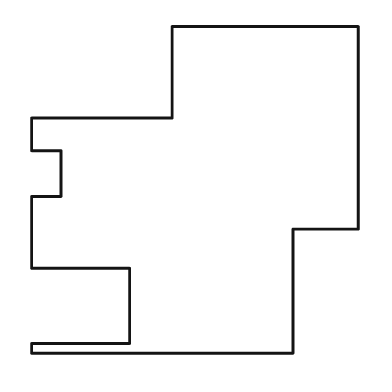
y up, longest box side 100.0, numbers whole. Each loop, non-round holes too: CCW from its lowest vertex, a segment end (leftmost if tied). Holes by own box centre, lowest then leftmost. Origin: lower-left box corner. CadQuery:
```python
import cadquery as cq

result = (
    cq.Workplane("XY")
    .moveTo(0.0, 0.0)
    .lineTo(80.0, 0.0)
    .lineTo(80.0, 38.0)
    .lineTo(100.0, 38.0)
    .lineTo(100.0, 100.0)
    .lineTo(43.0, 100.0)
    .lineTo(43.0, 72.0)
    .lineTo(0.0, 72.0)
    .lineTo(0.0, 62.0)
    .lineTo(9.0, 62.0)
    .lineTo(9.0, 48.0)
    .lineTo(0.0, 48.0)
    .lineTo(0.0, 26.0)
    .lineTo(30.0, 26.0)
    .lineTo(30.0, 3.0)
    .lineTo(0.0, 3.0)
    .close()
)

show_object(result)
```